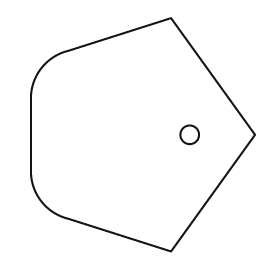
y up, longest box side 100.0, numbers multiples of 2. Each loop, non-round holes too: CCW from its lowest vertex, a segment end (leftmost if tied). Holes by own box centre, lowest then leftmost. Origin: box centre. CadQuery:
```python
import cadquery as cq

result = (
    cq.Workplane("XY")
    .moveTo(12.0, -50.0)
    .lineTo(48.0, 0.0)
    .lineTo(12.0, 50.0)
    .lineTo(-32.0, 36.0)
    .threePointArc((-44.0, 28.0), (-48.0, 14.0))
    .lineTo(-48.0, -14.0)
    .threePointArc((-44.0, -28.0), (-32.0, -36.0))
    .close()
    .moveTo(20.0, 0.0)
    .circle(4.0)
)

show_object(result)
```